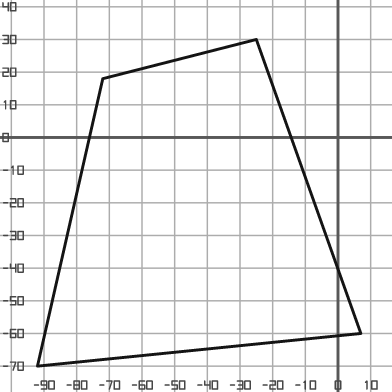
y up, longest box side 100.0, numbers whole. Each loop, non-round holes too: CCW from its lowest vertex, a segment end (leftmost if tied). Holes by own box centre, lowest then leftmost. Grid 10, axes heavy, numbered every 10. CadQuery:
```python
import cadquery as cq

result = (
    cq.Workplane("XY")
    .moveTo(-92.0, -70.0)
    .lineTo(7.0, -60.0)
    .lineTo(-25.0, 30.0)
    .lineTo(-72.0, 18.0)
    .close()
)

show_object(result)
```